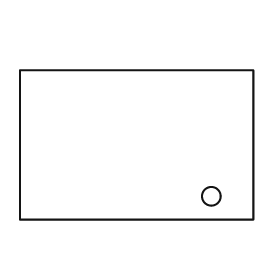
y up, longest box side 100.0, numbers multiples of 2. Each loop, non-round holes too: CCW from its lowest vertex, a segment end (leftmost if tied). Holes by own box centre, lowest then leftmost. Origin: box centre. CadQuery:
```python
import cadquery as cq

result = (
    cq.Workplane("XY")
    .moveTo(-50.0, -32.0)
    .lineTo(50.0, -32.0)
    .lineTo(50.0, 32.0)
    .lineTo(-50.0, 32.0)
    .close()
    .moveTo(32.0, -22.0)
    .circle(4.0)
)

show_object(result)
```